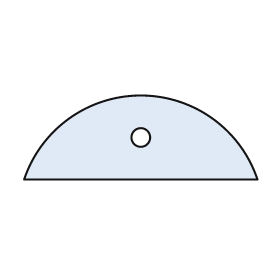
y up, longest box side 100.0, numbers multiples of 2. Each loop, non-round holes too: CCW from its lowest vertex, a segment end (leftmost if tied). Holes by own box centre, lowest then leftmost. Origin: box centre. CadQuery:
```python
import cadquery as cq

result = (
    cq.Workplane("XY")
    .moveTo(-50.0, -18.0)
    .lineTo(50.0, -18.0)
    .threePointArc((0.0, 18.0), (-50.0, -18.0))
    .close()
    .moveTo(0.0, 0.0)
    .circle(4.0)
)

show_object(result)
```